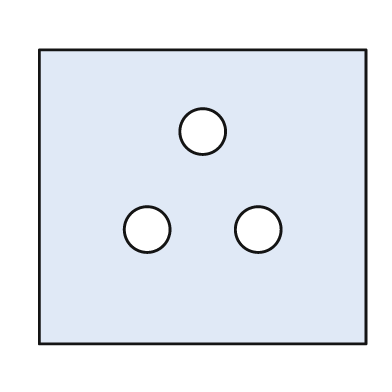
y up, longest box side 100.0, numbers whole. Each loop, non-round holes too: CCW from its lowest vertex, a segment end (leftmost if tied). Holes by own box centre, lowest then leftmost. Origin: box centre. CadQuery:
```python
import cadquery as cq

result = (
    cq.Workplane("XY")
    .moveTo(-50.0, -45.0)
    .lineTo(50.0, -45.0)
    .lineTo(50.0, 45.0)
    .lineTo(-50.0, 45.0)
    .close()
    .moveTo(-17.0, -10.0)
    .circle(7.0)
    .moveTo(17.0, -10.0)
    .circle(7.0)
    .moveTo(0.0, 20.0)
    .circle(7.0)
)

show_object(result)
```